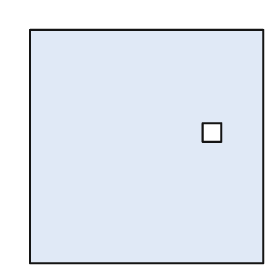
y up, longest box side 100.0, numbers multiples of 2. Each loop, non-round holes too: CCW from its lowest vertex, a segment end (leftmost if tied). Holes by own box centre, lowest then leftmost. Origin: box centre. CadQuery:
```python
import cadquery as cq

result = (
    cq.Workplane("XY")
    .moveTo(-50.0, -50.0)
    .lineTo(50.0, -50.0)
    .lineTo(50.0, 50.0)
    .lineTo(-50.0, 50.0)
    .close()
    .moveTo(24.0, 2.0)
    .lineTo(32.0, 2.0)
    .lineTo(32.0, 10.0)
    .lineTo(24.0, 10.0)
    .close()
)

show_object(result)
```